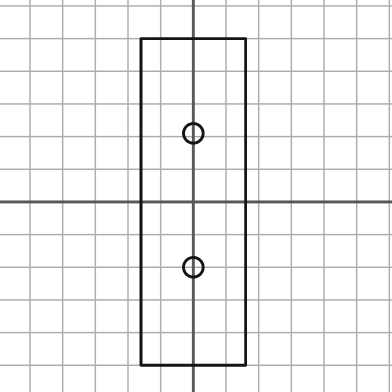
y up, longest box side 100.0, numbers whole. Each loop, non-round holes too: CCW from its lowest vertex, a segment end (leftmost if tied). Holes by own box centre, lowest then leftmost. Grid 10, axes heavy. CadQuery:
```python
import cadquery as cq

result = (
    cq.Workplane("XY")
    .moveTo(-16.0, -50.0)
    .lineTo(16.0, -50.0)
    .lineTo(16.0, 50.0)
    .lineTo(-16.0, 50.0)
    .close()
    .moveTo(0.0, -20.0)
    .circle(3.0)
    .moveTo(0.0, 21.0)
    .circle(3.0)
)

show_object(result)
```